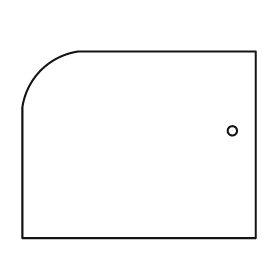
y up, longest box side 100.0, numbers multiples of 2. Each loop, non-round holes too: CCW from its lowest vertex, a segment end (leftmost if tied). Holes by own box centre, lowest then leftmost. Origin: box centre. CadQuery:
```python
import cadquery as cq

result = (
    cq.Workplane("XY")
    .moveTo(-50.0, -40.0)
    .lineTo(50.0, -40.0)
    .lineTo(50.0, 40.0)
    .lineTo(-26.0, 40.0)
    .threePointArc((-42.0, 32.0), (-50.0, 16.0))
    .close()
    .moveTo(40.0, 6.0)
    .circle(2.0)
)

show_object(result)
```